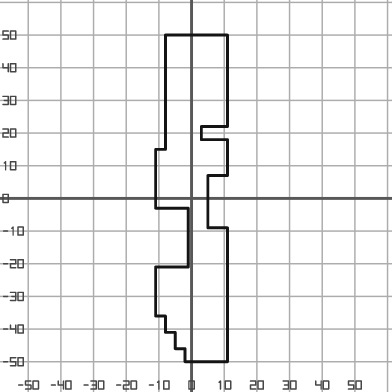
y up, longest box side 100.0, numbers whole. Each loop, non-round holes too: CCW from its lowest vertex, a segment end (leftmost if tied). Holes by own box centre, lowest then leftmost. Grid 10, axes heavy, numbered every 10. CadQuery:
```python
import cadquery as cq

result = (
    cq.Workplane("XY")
    .moveTo(-2.0, -50.0)
    .lineTo(11.0, -50.0)
    .lineTo(11.0, -9.0)
    .lineTo(5.0, -9.0)
    .lineTo(5.0, 7.0)
    .lineTo(11.0, 7.0)
    .lineTo(11.0, 18.0)
    .lineTo(3.0, 18.0)
    .lineTo(3.0, 22.0)
    .lineTo(11.0, 22.0)
    .lineTo(11.0, 50.0)
    .lineTo(-8.0, 50.0)
    .lineTo(-8.0, 15.0)
    .lineTo(-11.0, 15.0)
    .lineTo(-11.0, -3.0)
    .lineTo(-1.0, -3.0)
    .lineTo(-1.0, -21.0)
    .lineTo(-11.0, -21.0)
    .lineTo(-11.0, -36.0)
    .lineTo(-8.0, -36.0)
    .lineTo(-8.0, -41.0)
    .lineTo(-5.0, -41.0)
    .lineTo(-5.0, -46.0)
    .lineTo(-2.0, -46.0)
    .close()
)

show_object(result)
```